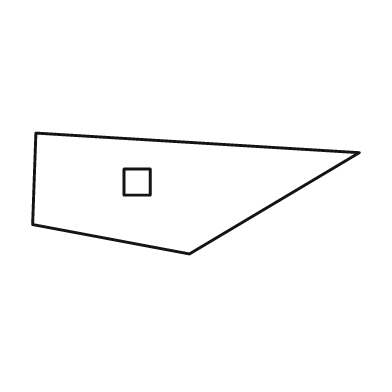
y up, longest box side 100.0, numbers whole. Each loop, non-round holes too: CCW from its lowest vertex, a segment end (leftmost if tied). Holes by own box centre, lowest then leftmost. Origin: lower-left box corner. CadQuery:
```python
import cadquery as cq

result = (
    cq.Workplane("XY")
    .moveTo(48.0, 0.0)
    .lineTo(100.0, 31.0)
    .lineTo(1.0, 37.0)
    .lineTo(0.0, 9.0)
    .close()
    .moveTo(28.0, 18.0)
    .lineTo(36.0, 18.0)
    .lineTo(36.0, 26.0)
    .lineTo(28.0, 26.0)
    .close()
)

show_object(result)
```